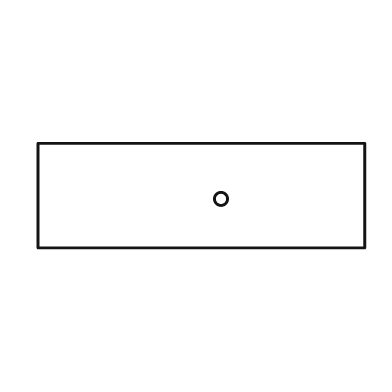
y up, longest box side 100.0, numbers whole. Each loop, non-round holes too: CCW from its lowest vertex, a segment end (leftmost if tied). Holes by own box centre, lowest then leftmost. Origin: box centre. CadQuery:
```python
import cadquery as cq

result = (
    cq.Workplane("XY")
    .moveTo(-50.0, -16.0)
    .lineTo(50.0, -16.0)
    .lineTo(50.0, 16.0)
    .lineTo(-50.0, 16.0)
    .close()
    .moveTo(6.0, -1.0)
    .circle(2.0)
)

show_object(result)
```